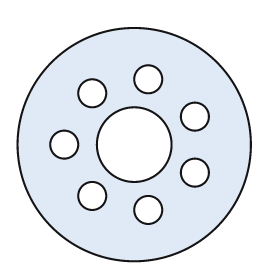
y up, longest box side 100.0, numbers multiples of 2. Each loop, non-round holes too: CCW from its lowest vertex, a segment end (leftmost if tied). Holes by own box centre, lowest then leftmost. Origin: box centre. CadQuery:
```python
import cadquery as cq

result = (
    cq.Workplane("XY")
    .moveTo(0.0, 0.0)
    .circle(50.0)
    .moveTo(6.0, -28.0)
    .circle(6.0)
    .moveTo(-18.0, -22.0)
    .circle(6.0)
    .moveTo(26.0, -12.0)
    .circle(6.0)
    .moveTo(-30.0, 0.0)
    .circle(6.0)
    .moveTo(0.0, 0.0)
    .circle(16.0)
    .moveTo(26.0, 12.0)
    .circle(6.0)
    .moveTo(-18.0, 22.0)
    .circle(6.0)
    .moveTo(6.0, 28.0)
    .circle(6.0)
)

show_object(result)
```